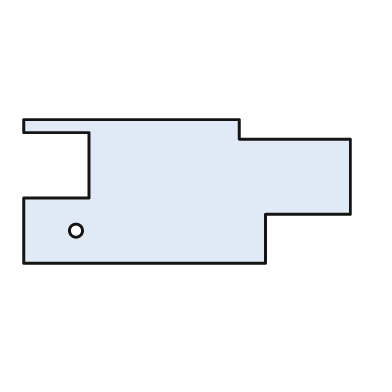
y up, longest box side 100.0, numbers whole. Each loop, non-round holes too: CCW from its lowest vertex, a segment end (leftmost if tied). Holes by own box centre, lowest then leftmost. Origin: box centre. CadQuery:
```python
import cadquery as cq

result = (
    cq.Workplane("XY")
    .moveTo(-50.0, -22.0)
    .lineTo(24.0, -22.0)
    .lineTo(24.0, -7.0)
    .lineTo(50.0, -7.0)
    .lineTo(50.0, 16.0)
    .lineTo(16.0, 16.0)
    .lineTo(16.0, 22.0)
    .lineTo(-50.0, 22.0)
    .lineTo(-50.0, 18.0)
    .lineTo(-30.0, 18.0)
    .lineTo(-30.0, -2.0)
    .lineTo(-50.0, -2.0)
    .close()
    .moveTo(-34.0, -12.0)
    .circle(2.0)
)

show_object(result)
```